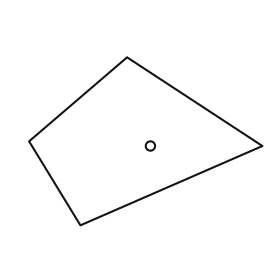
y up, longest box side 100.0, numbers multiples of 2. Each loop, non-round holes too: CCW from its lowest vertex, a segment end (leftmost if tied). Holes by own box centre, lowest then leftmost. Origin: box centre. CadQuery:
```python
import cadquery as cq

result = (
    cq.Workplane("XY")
    .moveTo(-28.0, -36.0)
    .lineTo(50.0, -2.0)
    .lineTo(-8.0, 36.0)
    .lineTo(-50.0, 0.0)
    .close()
    .moveTo(2.0, -2.0)
    .circle(2.0)
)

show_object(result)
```